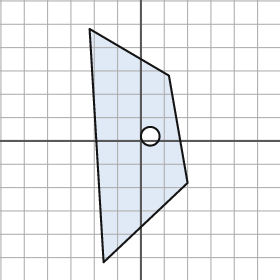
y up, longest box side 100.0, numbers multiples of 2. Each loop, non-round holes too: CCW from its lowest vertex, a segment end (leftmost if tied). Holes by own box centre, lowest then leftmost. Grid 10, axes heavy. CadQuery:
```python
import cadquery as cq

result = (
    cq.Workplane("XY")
    .moveTo(-16.0, -52.0)
    .lineTo(20.0, -18.0)
    .lineTo(12.0, 28.0)
    .lineTo(-22.0, 48.0)
    .close()
    .moveTo(4.0, 2.0)
    .circle(4.0)
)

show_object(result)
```